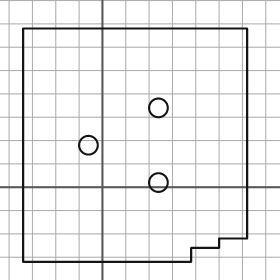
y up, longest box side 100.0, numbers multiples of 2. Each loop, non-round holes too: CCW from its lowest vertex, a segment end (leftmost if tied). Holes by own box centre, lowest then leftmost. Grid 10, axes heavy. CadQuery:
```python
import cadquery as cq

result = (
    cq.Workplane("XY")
    .moveTo(-34.0, -32.0)
    .lineTo(38.0, -32.0)
    .lineTo(38.0, -26.0)
    .lineTo(50.0, -26.0)
    .lineTo(50.0, -22.0)
    .lineTo(62.0, -22.0)
    .lineTo(62.0, 68.0)
    .lineTo(-34.0, 68.0)
    .close()
    .moveTo(24.0, 2.0)
    .circle(4.0)
    .moveTo(-6.0, 18.0)
    .circle(4.0)
    .moveTo(24.0, 34.0)
    .circle(4.0)
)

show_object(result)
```